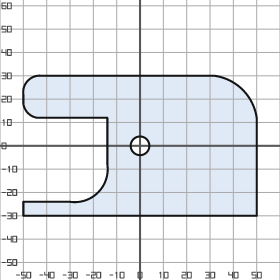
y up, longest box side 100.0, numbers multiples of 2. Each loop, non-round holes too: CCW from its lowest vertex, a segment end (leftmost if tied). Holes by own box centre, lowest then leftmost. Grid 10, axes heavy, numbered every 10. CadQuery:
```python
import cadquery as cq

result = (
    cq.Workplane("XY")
    .moveTo(-50.0, -30.0)
    .lineTo(50.0, -30.0)
    .lineTo(50.0, 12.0)
    .threePointArc((44.0, 24.0), (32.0, 30.0))
    .lineTo(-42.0, 30.0)
    .threePointArc((-48.0, 28.0), (-50.0, 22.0))
    .lineTo(-50.0, 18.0)
    .threePointArc((-48.0, 14.0), (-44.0, 12.0))
    .lineTo(-14.0, 12.0)
    .lineTo(-14.0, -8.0)
    .threePointArc((-18.0, -20.0), (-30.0, -24.0))
    .lineTo(-50.0, -24.0)
    .close()
    .moveTo(0.0, 0.0)
    .circle(4.0)
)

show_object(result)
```